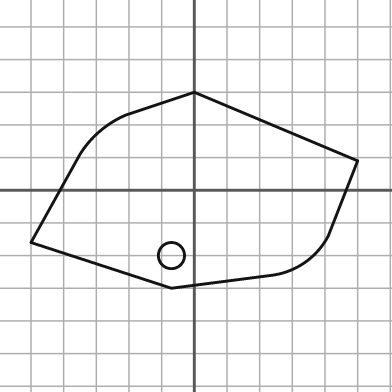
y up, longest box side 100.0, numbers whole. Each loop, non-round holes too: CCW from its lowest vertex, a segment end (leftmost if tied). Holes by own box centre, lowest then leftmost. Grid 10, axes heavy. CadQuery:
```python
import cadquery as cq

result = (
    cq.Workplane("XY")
    .moveTo(-7.0, -30.0)
    .lineTo(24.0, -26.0)
    .threePointArc((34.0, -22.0), (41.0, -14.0))
    .lineTo(50.0, 9.0)
    .lineTo(0.0, 30.0)
    .lineTo(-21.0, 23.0)
    .threePointArc((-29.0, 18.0), (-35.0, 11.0))
    .lineTo(-50.0, -16.0)
    .close()
    .moveTo(-7.0, -20.0)
    .circle(4.0)
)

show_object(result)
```